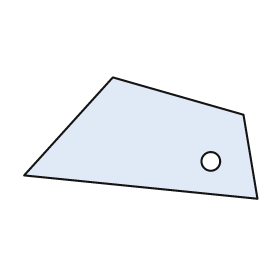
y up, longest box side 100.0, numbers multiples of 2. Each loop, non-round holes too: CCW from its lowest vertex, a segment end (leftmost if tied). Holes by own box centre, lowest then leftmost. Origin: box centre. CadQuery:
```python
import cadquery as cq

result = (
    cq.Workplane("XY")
    .moveTo(50.0, -26.0)
    .lineTo(44.0, 10.0)
    .lineTo(-12.0, 26.0)
    .lineTo(-50.0, -16.0)
    .close()
    .moveTo(30.0, -10.0)
    .circle(4.0)
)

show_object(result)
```